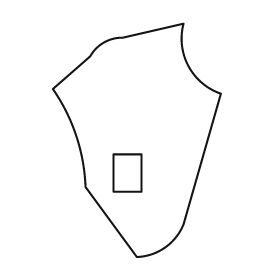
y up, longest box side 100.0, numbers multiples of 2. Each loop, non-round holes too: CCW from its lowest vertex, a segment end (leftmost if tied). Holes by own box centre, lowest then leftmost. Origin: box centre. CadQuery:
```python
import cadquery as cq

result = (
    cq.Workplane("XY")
    .moveTo(0.0, -50.0)
    .threePointArc((12.0, -46.0), (20.0, -36.0))
    .lineTo(36.0, 20.0)
    .threePointArc((22.0, 32.0), (20.0, 50.0))
    .lineTo(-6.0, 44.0)
    .threePointArc((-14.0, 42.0), (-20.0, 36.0))
    .lineTo(-36.0, 22.0)
    .threePointArc((-26.0, 2.0), (-22.0, -20.0))
    .close()
    .moveTo(-10.0, -22.0)
    .lineTo(2.0, -22.0)
    .lineTo(2.0, -6.0)
    .lineTo(-10.0, -6.0)
    .close()
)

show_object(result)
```